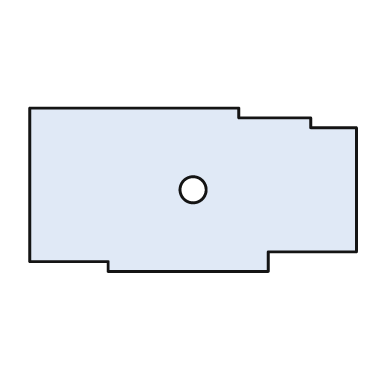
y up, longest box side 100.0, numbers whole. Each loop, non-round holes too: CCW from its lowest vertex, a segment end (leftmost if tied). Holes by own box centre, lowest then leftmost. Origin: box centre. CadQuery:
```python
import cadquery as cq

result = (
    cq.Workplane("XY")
    .moveTo(-26.0, -25.0)
    .lineTo(23.0, -25.0)
    .lineTo(23.0, -19.0)
    .lineTo(50.0, -19.0)
    .lineTo(50.0, 19.0)
    .lineTo(36.0, 19.0)
    .lineTo(36.0, 22.0)
    .lineTo(14.0, 22.0)
    .lineTo(14.0, 25.0)
    .lineTo(-50.0, 25.0)
    .lineTo(-50.0, -22.0)
    .lineTo(-26.0, -22.0)
    .close()
    .moveTo(0.0, 0.0)
    .circle(4.0)
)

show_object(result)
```